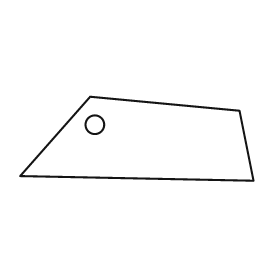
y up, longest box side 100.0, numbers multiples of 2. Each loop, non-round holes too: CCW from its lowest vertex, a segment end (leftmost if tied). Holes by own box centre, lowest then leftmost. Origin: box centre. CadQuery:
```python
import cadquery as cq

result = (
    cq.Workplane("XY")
    .moveTo(50.0, -18.0)
    .lineTo(44.0, 12.0)
    .lineTo(-20.0, 18.0)
    .lineTo(-50.0, -16.0)
    .close()
    .moveTo(-18.0, 6.0)
    .circle(4.0)
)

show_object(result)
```